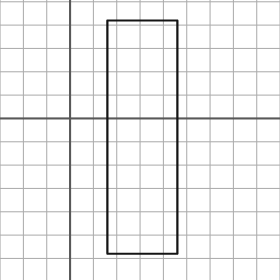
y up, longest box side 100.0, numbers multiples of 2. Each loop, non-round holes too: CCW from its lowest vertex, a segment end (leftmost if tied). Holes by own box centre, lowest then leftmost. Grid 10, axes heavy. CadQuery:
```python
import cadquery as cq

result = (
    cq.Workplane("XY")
    .moveTo(16.0, -58.0)
    .lineTo(46.0, -58.0)
    .lineTo(46.0, 42.0)
    .lineTo(16.0, 42.0)
    .close()
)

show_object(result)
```